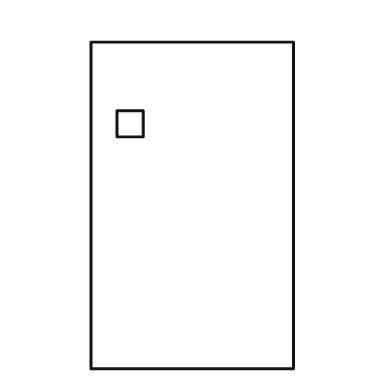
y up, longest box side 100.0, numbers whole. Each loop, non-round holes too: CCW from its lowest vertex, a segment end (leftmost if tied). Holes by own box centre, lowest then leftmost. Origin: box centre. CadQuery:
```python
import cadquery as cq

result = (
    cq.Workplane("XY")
    .moveTo(-31.0, -50.0)
    .lineTo(31.0, -50.0)
    .lineTo(31.0, 50.0)
    .lineTo(-31.0, 50.0)
    .close()
    .moveTo(-23.0, 21.0)
    .lineTo(-15.0, 21.0)
    .lineTo(-15.0, 29.0)
    .lineTo(-23.0, 29.0)
    .close()
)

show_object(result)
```